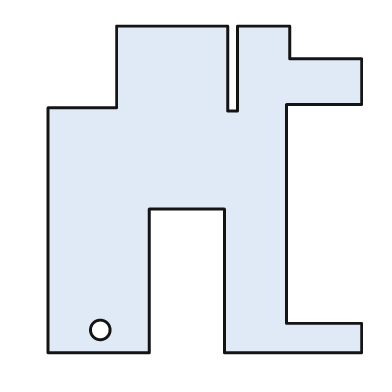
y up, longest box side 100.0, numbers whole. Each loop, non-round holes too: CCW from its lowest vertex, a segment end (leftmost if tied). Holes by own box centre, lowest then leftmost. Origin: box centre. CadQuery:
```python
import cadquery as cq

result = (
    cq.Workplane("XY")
    .moveTo(-48.0, -50.0)
    .lineTo(-17.0, -50.0)
    .lineTo(-17.0, -6.0)
    .lineTo(6.0, -6.0)
    .lineTo(6.0, -50.0)
    .lineTo(48.0, -50.0)
    .lineTo(48.0, -41.0)
    .lineTo(25.0, -41.0)
    .lineTo(25.0, 26.0)
    .lineTo(48.0, 26.0)
    .lineTo(48.0, 40.0)
    .lineTo(26.0, 40.0)
    .lineTo(26.0, 50.0)
    .lineTo(10.0, 50.0)
    .lineTo(10.0, 24.0)
    .lineTo(7.0, 24.0)
    .lineTo(7.0, 50.0)
    .lineTo(-27.0, 50.0)
    .lineTo(-27.0, 25.0)
    .lineTo(-48.0, 25.0)
    .close()
    .moveTo(-32.0, -43.0)
    .circle(3.0)
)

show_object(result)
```